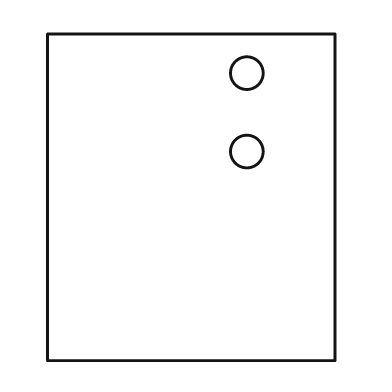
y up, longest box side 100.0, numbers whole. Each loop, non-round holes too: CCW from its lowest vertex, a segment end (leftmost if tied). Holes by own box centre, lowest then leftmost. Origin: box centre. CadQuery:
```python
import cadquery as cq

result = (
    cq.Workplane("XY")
    .moveTo(-44.0, -50.0)
    .lineTo(44.0, -50.0)
    .lineTo(44.0, 50.0)
    .lineTo(-44.0, 50.0)
    .close()
    .moveTo(17.0, 14.0)
    .circle(5.0)
    .moveTo(17.0, 38.0)
    .circle(5.0)
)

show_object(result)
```